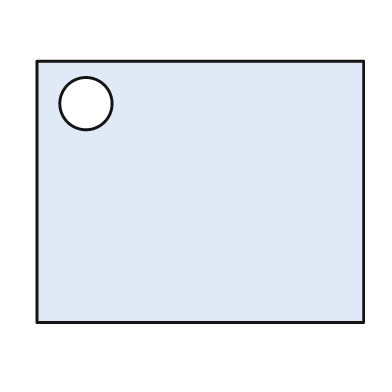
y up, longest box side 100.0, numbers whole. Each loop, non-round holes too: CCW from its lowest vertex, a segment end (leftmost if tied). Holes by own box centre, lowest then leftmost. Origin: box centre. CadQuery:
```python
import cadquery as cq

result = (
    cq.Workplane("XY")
    .moveTo(-50.0, -40.0)
    .lineTo(50.0, -40.0)
    .lineTo(50.0, 40.0)
    .lineTo(-50.0, 40.0)
    .close()
    .moveTo(-35.0, 27.0)
    .circle(8.0)
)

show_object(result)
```